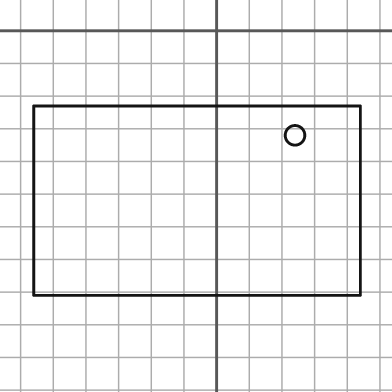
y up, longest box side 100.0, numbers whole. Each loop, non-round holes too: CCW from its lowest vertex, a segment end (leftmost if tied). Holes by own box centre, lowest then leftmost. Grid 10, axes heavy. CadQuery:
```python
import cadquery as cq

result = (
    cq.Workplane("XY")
    .moveTo(-56.0, -81.0)
    .lineTo(44.0, -81.0)
    .lineTo(44.0, -23.0)
    .lineTo(-56.0, -23.0)
    .close()
    .moveTo(24.0, -32.0)
    .circle(3.0)
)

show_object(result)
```